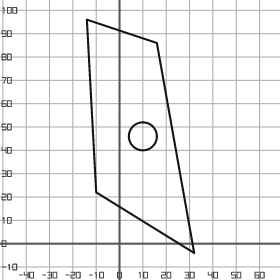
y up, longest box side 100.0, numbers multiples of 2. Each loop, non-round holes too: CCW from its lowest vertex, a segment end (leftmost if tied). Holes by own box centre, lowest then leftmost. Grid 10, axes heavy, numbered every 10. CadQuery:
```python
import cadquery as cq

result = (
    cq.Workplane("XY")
    .moveTo(32.0, -4.0)
    .lineTo(16.0, 86.0)
    .lineTo(-14.0, 96.0)
    .lineTo(-10.0, 22.0)
    .close()
    .moveTo(10.0, 46.0)
    .circle(6.0)
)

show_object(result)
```